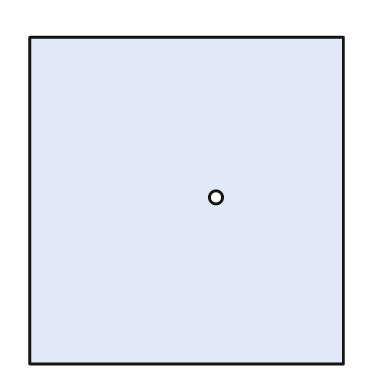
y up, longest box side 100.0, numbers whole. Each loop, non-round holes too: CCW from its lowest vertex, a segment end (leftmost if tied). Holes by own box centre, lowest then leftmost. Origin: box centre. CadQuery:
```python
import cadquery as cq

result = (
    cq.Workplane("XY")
    .moveTo(-48.0, -50.0)
    .lineTo(48.0, -50.0)
    .lineTo(48.0, 50.0)
    .lineTo(-48.0, 50.0)
    .close()
    .moveTo(9.0, 1.0)
    .circle(2.0)
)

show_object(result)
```